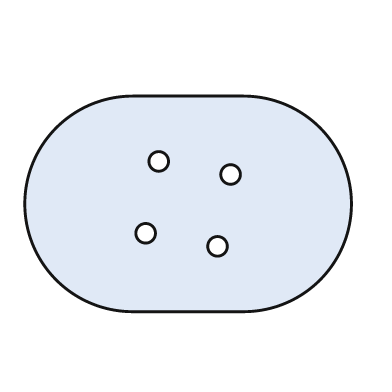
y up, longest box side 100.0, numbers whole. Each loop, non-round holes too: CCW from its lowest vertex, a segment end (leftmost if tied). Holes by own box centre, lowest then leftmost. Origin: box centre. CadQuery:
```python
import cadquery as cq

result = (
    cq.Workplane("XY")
    .moveTo(-17.0, -33.0)
    .lineTo(17.0, -33.0)
    .threePointArc((50.0, 0.0), (17.0, 33.0))
    .lineTo(-17.0, 33.0)
    .threePointArc((-50.0, 0.0), (-17.0, -33.0))
    .close()
    .moveTo(9.0, -13.0)
    .circle(3.0)
    .moveTo(-13.0, -9.0)
    .circle(3.0)
    .moveTo(13.0, 9.0)
    .circle(3.0)
    .moveTo(-9.0, 13.0)
    .circle(3.0)
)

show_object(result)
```